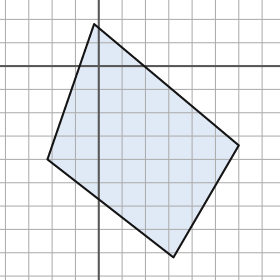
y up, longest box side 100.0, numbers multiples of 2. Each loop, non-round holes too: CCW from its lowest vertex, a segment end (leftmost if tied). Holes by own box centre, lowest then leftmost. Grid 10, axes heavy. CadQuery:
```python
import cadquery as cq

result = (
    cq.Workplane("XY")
    .moveTo(32.0, -82.0)
    .lineTo(60.0, -34.0)
    .lineTo(-2.0, 18.0)
    .lineTo(-22.0, -40.0)
    .close()
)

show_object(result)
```